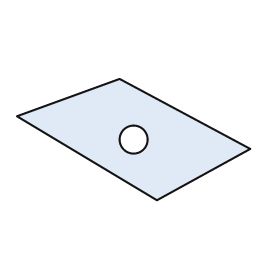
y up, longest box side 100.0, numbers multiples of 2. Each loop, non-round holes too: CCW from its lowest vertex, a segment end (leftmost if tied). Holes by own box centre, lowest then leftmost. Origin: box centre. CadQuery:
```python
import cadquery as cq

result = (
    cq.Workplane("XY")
    .moveTo(10.0, -26.0)
    .lineTo(50.0, -4.0)
    .lineTo(-6.0, 26.0)
    .lineTo(-50.0, 10.0)
    .close()
    .moveTo(0.0, 0.0)
    .circle(6.0)
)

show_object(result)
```